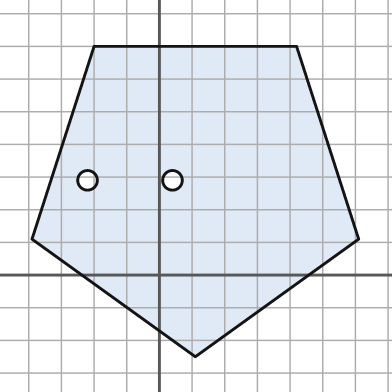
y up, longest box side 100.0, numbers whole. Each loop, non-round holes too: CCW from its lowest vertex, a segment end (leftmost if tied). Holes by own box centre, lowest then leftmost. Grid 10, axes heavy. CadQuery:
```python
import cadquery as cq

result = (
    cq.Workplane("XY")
    .moveTo(11.0, -25.0)
    .lineTo(61.0, 11.0)
    .lineTo(42.0, 70.0)
    .lineTo(-20.0, 70.0)
    .lineTo(-39.0, 11.0)
    .close()
    .moveTo(-22.0, 29.0)
    .circle(3.0)
    .moveTo(4.0, 29.0)
    .circle(3.0)
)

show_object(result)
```